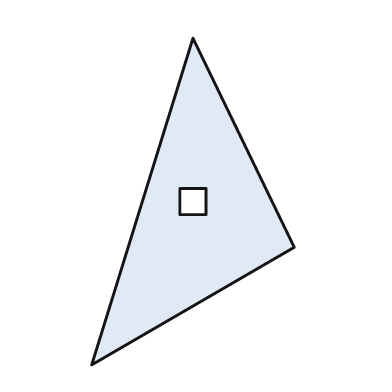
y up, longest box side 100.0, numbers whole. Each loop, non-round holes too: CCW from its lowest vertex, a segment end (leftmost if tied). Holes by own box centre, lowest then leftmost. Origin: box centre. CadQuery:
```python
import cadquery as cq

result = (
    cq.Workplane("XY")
    .moveTo(-31.0, -50.0)
    .lineTo(31.0, -14.0)
    .lineTo(0.0, 50.0)
    .close()
    .moveTo(-4.0, -4.0)
    .lineTo(4.0, -4.0)
    .lineTo(4.0, 4.0)
    .lineTo(-4.0, 4.0)
    .close()
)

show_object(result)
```